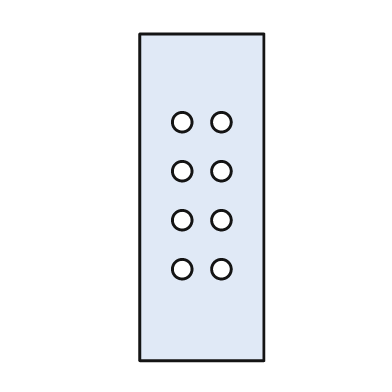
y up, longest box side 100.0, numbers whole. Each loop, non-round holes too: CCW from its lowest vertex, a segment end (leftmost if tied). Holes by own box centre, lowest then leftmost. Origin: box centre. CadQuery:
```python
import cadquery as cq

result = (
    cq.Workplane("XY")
    .moveTo(-19.0, -50.0)
    .lineTo(19.0, -50.0)
    .lineTo(19.0, 50.0)
    .lineTo(-19.0, 50.0)
    .close()
    .moveTo(-6.0, -22.0)
    .circle(3.0)
    .moveTo(6.0, -22.0)
    .circle(3.0)
    .moveTo(-6.0, -7.0)
    .circle(3.0)
    .moveTo(6.0, -7.0)
    .circle(3.0)
    .moveTo(-6.0, 8.0)
    .circle(3.0)
    .moveTo(6.0, 8.0)
    .circle(3.0)
    .moveTo(-6.0, 23.0)
    .circle(3.0)
    .moveTo(6.0, 23.0)
    .circle(3.0)
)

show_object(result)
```